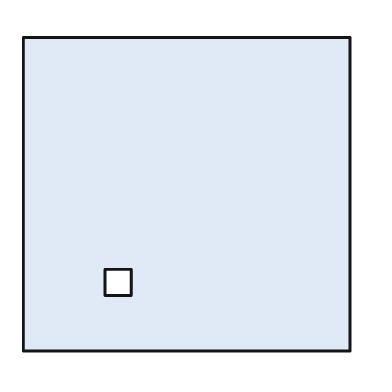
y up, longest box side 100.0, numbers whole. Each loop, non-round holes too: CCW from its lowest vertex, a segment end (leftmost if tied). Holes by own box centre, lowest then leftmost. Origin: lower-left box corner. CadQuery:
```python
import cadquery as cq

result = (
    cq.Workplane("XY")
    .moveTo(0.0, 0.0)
    .lineTo(100.0, 0.0)
    .lineTo(100.0, 96.0)
    .lineTo(0.0, 96.0)
    .close()
    .moveTo(25.0, 17.0)
    .lineTo(33.0, 17.0)
    .lineTo(33.0, 25.0)
    .lineTo(25.0, 25.0)
    .close()
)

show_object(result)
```